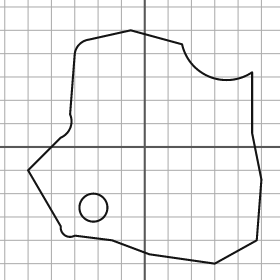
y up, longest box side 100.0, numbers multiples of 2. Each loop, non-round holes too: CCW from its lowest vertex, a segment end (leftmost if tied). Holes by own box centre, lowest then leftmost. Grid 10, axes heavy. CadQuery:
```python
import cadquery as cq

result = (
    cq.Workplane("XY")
    .moveTo(30.0, -50.0)
    .lineTo(48.0, -40.0)
    .lineTo(50.0, -14.0)
    .lineTo(46.0, 6.0)
    .lineTo(46.0, 32.0)
    .threePointArc((28.0, 30.0), (16.0, 44.0))
    .lineTo(-6.0, 50.0)
    .lineTo(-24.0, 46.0)
    .threePointArc((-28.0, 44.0), (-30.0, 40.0))
    .lineTo(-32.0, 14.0)
    .threePointArc((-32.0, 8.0), (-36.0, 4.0))
    .lineTo(-50.0, -10.0)
    .lineTo(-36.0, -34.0)
    .threePointArc((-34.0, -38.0), (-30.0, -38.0))
    .lineTo(-14.0, -40.0)
    .lineTo(2.0, -46.0)
    .close()
    .moveTo(-22.0, -26.0)
    .circle(6.0)
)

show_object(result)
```